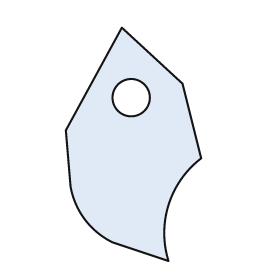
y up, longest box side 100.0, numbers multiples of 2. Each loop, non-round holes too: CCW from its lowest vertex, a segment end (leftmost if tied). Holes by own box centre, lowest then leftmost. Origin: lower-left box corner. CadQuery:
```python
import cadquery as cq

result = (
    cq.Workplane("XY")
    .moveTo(44.0, 0.0)
    .threePointArc((44.0, 24.0), (58.0, 44.0))
    .lineTo(50.0, 76.0)
    .lineTo(24.0, 100.0)
    .lineTo(0.0, 56.0)
    .lineTo(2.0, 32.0)
    .threePointArc((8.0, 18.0), (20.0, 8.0))
    .close()
    .moveTo(28.0, 70.0)
    .circle(8.0)
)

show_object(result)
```